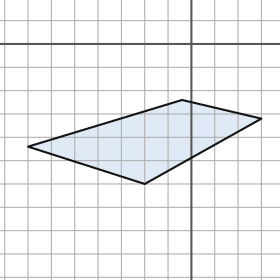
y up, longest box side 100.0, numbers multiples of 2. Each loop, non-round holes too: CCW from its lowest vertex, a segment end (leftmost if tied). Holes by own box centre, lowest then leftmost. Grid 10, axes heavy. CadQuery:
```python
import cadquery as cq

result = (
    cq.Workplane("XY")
    .moveTo(-20.0, -60.0)
    .lineTo(30.0, -32.0)
    .lineTo(-4.0, -24.0)
    .lineTo(-70.0, -44.0)
    .close()
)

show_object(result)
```